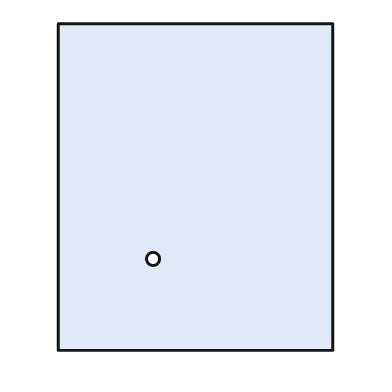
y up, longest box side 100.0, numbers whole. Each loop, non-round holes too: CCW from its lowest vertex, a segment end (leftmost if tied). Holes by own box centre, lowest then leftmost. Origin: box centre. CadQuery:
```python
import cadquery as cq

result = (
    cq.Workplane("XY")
    .moveTo(-42.0, -50.0)
    .lineTo(42.0, -50.0)
    .lineTo(42.0, 50.0)
    .lineTo(-42.0, 50.0)
    .close()
    .moveTo(-13.0, -22.0)
    .circle(2.0)
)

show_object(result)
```